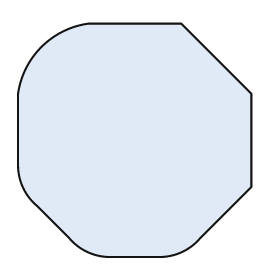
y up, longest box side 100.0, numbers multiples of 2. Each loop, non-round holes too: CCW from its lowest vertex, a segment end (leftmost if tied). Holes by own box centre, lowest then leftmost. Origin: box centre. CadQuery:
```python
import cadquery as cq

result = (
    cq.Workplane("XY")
    .moveTo(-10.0, -50.0)
    .lineTo(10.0, -50.0)
    .threePointArc((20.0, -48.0), (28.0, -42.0))
    .lineTo(50.0, -20.0)
    .lineTo(50.0, 20.0)
    .lineTo(20.0, 50.0)
    .lineTo(-20.0, 50.0)
    .threePointArc((-40.0, 40.0), (-50.0, 20.0))
    .lineTo(-50.0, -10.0)
    .threePointArc((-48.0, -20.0), (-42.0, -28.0))
    .lineTo(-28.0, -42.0)
    .threePointArc((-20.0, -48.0), (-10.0, -50.0))
    .close()
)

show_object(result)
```